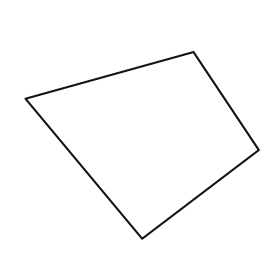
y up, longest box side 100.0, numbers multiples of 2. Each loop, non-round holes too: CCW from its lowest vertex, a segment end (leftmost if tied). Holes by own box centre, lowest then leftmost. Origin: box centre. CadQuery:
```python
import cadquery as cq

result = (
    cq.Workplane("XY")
    .moveTo(0.0, -40.0)
    .lineTo(50.0, -2.0)
    .lineTo(22.0, 40.0)
    .lineTo(-50.0, 20.0)
    .close()
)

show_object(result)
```